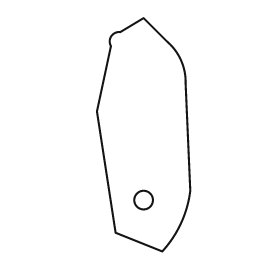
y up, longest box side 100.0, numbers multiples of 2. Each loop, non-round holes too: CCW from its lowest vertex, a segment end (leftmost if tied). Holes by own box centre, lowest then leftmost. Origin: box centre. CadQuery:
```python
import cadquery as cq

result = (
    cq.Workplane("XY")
    .moveTo(8.0, -50.0)
    .threePointArc((16.0, -38.0), (20.0, -24.0))
    .lineTo(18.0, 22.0)
    .threePointArc((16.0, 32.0), (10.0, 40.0))
    .lineTo(0.0, 50.0)
    .lineTo(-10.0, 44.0)
    .threePointArc((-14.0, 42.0), (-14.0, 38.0))
    .lineTo(-20.0, 10.0)
    .lineTo(-12.0, -42.0)
    .close()
    .moveTo(0.0, -28.0)
    .circle(4.0)
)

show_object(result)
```